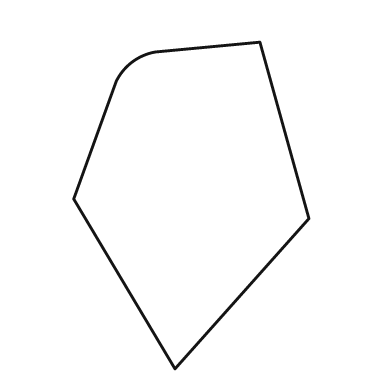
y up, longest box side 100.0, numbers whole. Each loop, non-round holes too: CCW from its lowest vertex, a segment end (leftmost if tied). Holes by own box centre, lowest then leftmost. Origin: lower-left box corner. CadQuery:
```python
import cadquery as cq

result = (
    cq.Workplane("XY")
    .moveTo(31.0, 0.0)
    .lineTo(72.0, 46.0)
    .lineTo(57.0, 100.0)
    .lineTo(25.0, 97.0)
    .threePointArc((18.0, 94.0), (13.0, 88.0))
    .lineTo(0.0, 52.0)
    .close()
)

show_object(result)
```